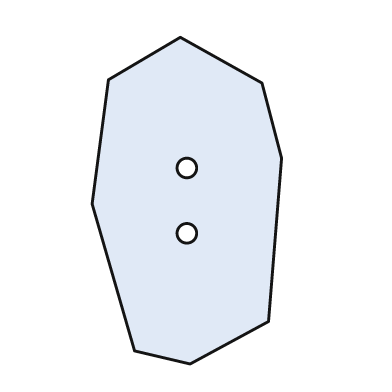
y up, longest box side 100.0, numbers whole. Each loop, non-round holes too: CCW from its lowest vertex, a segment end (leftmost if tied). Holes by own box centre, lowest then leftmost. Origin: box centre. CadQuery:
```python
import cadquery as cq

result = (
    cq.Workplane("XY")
    .moveTo(1.0, -50.0)
    .lineTo(25.0, -37.0)
    .lineTo(29.0, 13.0)
    .lineTo(23.0, 36.0)
    .lineTo(-2.0, 50.0)
    .lineTo(-24.0, 37.0)
    .lineTo(-29.0, -1.0)
    .lineTo(-16.0, -46.0)
    .close()
    .moveTo(0.0, -10.0)
    .circle(3.0)
    .moveTo(0.0, 10.0)
    .circle(3.0)
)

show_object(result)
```